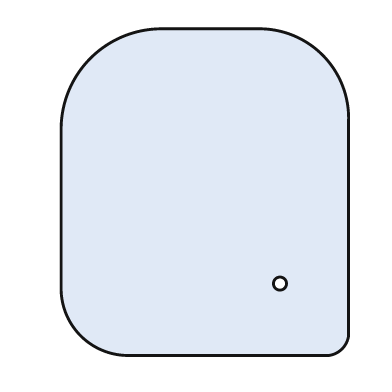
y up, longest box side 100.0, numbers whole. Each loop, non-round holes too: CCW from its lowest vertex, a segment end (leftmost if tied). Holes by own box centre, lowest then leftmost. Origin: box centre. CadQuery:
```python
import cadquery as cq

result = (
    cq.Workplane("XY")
    .moveTo(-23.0, -50.0)
    .lineTo(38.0, -50.0)
    .threePointArc((42.0, -48.0), (44.0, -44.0))
    .lineTo(44.0, 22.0)
    .threePointArc((36.0, 42.0), (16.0, 50.0))
    .lineTo(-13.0, 50.0)
    .threePointArc((-35.0, 41.0), (-44.0, 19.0))
    .lineTo(-44.0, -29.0)
    .threePointArc((-38.0, -44.0), (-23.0, -50.0))
    .close()
    .moveTo(23.0, -28.0)
    .circle(2.0)
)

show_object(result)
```